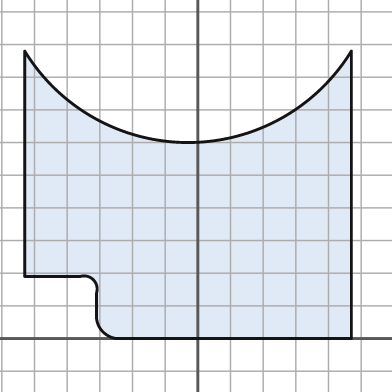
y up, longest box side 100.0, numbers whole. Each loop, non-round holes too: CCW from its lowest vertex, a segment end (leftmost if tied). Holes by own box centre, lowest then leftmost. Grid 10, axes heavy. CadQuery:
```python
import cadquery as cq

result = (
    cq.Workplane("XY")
    .moveTo(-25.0, 0.0)
    .lineTo(47.0, 0.0)
    .lineTo(47.0, 88.0)
    .threePointArc((-3.0, 60.0), (-53.0, 88.0))
    .lineTo(-53.0, 19.0)
    .lineTo(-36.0, 19.0)
    .threePointArc((-32.0, 18.0), (-31.0, 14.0))
    .lineTo(-31.0, 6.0)
    .threePointArc((-29.0, 2.0), (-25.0, 0.0))
    .close()
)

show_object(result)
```